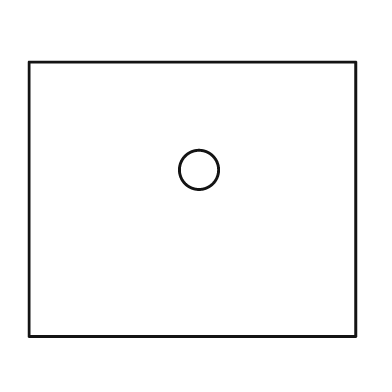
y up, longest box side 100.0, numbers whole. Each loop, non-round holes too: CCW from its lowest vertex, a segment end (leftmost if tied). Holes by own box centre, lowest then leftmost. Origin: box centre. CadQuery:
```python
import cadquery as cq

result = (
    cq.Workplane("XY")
    .moveTo(-50.0, -42.0)
    .lineTo(50.0, -42.0)
    .lineTo(50.0, 42.0)
    .lineTo(-50.0, 42.0)
    .close()
    .moveTo(2.0, 9.0)
    .circle(6.0)
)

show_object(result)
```